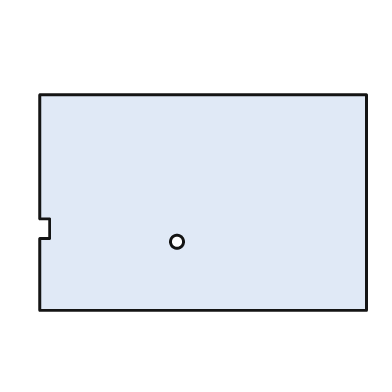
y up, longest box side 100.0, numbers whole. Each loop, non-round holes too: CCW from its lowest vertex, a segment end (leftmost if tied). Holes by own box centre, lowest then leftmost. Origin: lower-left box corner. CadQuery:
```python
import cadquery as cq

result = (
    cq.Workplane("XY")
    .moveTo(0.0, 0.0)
    .lineTo(100.0, 0.0)
    .lineTo(100.0, 66.0)
    .lineTo(0.0, 66.0)
    .lineTo(0.0, 28.0)
    .lineTo(3.0, 28.0)
    .lineTo(3.0, 22.0)
    .lineTo(0.0, 22.0)
    .close()
    .moveTo(42.0, 21.0)
    .circle(2.0)
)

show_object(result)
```